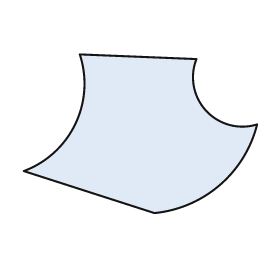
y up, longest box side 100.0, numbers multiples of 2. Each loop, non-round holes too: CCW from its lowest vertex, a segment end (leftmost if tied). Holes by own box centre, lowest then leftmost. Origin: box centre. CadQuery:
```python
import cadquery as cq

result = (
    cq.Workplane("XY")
    .moveTo(6.0, -34.0)
    .threePointArc((34.0, -22.0), (50.0, 4.0))
    .threePointArc((28.0, 10.0), (24.0, 32.0))
    .lineTo(-26.0, 34.0)
    .threePointArc((-28.0, 4.0), (-50.0, -16.0))
    .close()
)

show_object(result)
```